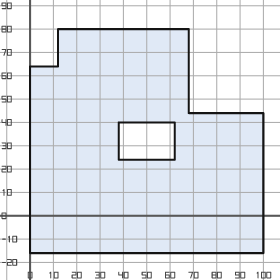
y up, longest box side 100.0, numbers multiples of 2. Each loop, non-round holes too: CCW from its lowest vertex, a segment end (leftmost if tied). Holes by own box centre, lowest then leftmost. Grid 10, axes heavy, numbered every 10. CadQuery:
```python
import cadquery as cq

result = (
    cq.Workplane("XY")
    .moveTo(0.0, -16.0)
    .lineTo(100.0, -16.0)
    .lineTo(100.0, 44.0)
    .lineTo(68.0, 44.0)
    .lineTo(68.0, 80.0)
    .lineTo(12.0, 80.0)
    .lineTo(12.0, 64.0)
    .lineTo(0.0, 64.0)
    .close()
    .moveTo(38.0, 24.0)
    .lineTo(62.0, 24.0)
    .lineTo(62.0, 40.0)
    .lineTo(38.0, 40.0)
    .close()
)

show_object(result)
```